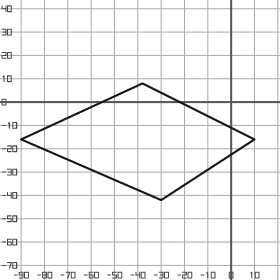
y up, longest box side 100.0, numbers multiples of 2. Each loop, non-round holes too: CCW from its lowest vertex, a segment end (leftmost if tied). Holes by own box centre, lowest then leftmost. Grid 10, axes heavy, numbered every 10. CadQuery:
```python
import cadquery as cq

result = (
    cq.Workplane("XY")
    .moveTo(-30.0, -42.0)
    .lineTo(10.0, -16.0)
    .lineTo(-38.0, 8.0)
    .lineTo(-90.0, -16.0)
    .close()
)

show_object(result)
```